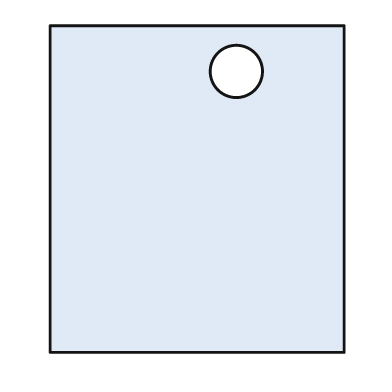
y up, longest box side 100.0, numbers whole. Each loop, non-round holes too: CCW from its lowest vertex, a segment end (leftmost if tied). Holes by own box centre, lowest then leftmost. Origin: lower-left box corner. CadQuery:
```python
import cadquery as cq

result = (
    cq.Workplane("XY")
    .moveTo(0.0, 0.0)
    .lineTo(90.0, 0.0)
    .lineTo(90.0, 100.0)
    .lineTo(0.0, 100.0)
    .close()
    .moveTo(57.0, 86.0)
    .circle(8.0)
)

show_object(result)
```